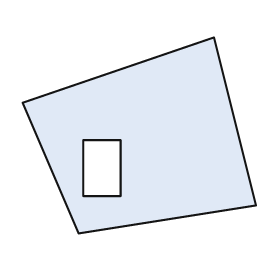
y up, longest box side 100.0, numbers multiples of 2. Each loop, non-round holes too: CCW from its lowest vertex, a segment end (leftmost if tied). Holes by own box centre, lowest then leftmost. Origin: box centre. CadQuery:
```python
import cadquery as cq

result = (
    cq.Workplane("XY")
    .moveTo(-26.0, -42.0)
    .lineTo(50.0, -30.0)
    .lineTo(32.0, 42.0)
    .lineTo(-50.0, 14.0)
    .close()
    .moveTo(-24.0, -26.0)
    .lineTo(-8.0, -26.0)
    .lineTo(-8.0, -2.0)
    .lineTo(-24.0, -2.0)
    .close()
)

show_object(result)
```